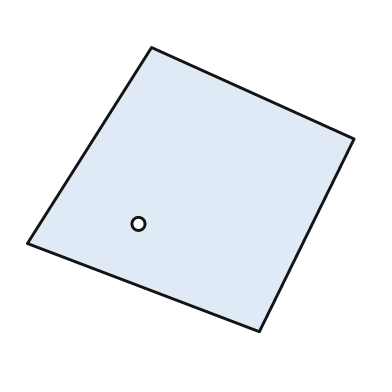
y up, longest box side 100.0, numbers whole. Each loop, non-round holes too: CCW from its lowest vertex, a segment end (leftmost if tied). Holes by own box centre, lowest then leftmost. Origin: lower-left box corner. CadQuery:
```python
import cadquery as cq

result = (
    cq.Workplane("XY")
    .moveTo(71.0, 0.0)
    .lineTo(100.0, 59.0)
    .lineTo(38.0, 87.0)
    .lineTo(0.0, 27.0)
    .close()
    .moveTo(34.0, 33.0)
    .circle(2.0)
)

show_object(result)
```